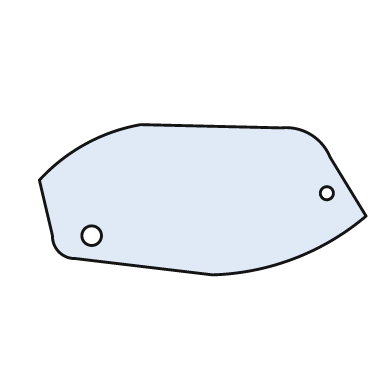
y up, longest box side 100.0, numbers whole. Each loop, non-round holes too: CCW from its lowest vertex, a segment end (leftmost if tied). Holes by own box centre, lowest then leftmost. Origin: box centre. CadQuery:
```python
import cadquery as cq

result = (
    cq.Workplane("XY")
    .moveTo(3.0, -23.0)
    .threePointArc((28.0, -18.0), (50.0, -5.0))
    .lineTo(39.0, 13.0)
    .threePointArc((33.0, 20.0), (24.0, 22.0))
    .lineTo(-19.0, 23.0)
    .threePointArc((-36.0, 17.0), (-50.0, 6.0))
    .lineTo(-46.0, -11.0)
    .threePointArc((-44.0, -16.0), (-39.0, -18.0))
    .close()
    .moveTo(-34.0, -11.0)
    .circle(3.0)
    .moveTo(38.0, 2.0)
    .circle(2.0)
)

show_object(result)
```